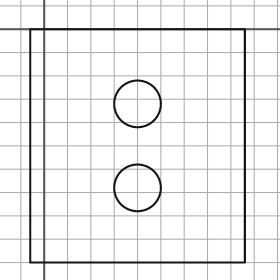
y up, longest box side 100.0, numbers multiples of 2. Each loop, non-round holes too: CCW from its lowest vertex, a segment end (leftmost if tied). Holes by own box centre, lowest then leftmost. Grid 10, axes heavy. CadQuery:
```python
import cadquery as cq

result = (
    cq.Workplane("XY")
    .moveTo(-6.0, -100.0)
    .lineTo(86.0, -100.0)
    .lineTo(86.0, 0.0)
    .lineTo(-6.0, 0.0)
    .close()
    .moveTo(40.0, -68.0)
    .circle(10.0)
    .moveTo(40.0, -32.0)
    .circle(10.0)
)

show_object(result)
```